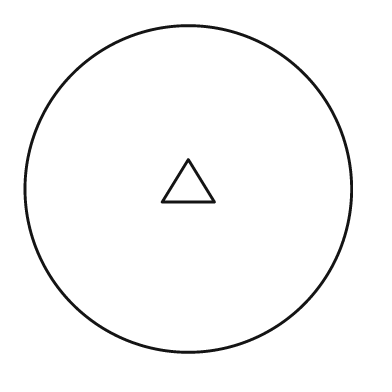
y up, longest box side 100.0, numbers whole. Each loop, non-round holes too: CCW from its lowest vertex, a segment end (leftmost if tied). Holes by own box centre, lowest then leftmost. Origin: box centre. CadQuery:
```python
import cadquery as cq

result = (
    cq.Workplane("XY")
    .moveTo(0.0, 0.0)
    .circle(50.0)
    .moveTo(-8.0, -4.0)
    .lineTo(8.0, -4.0)
    .lineTo(0.0, 9.0)
    .close()
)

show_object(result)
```